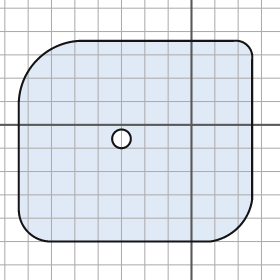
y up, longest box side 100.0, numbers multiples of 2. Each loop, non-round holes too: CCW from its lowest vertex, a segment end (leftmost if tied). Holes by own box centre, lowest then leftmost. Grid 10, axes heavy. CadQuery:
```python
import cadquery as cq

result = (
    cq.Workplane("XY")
    .moveTo(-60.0, -50.0)
    .lineTo(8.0, -50.0)
    .threePointArc((20.0, -44.0), (26.0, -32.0))
    .lineTo(26.0, 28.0)
    .threePointArc((24.0, 34.0), (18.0, 36.0))
    .lineTo(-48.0, 36.0)
    .threePointArc((-66.0, 28.0), (-74.0, 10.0))
    .lineTo(-74.0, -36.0)
    .threePointArc((-70.0, -46.0), (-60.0, -50.0))
    .close()
    .moveTo(-30.0, -6.0)
    .circle(4.0)
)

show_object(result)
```